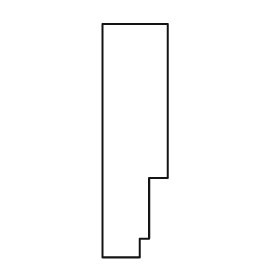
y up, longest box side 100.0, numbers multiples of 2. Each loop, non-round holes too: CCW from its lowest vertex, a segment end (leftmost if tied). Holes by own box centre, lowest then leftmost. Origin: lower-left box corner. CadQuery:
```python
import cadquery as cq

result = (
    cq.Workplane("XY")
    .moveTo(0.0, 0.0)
    .lineTo(16.0, 0.0)
    .lineTo(16.0, 8.0)
    .lineTo(20.0, 8.0)
    .lineTo(20.0, 34.0)
    .lineTo(28.0, 34.0)
    .lineTo(28.0, 100.0)
    .lineTo(0.0, 100.0)
    .close()
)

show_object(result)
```